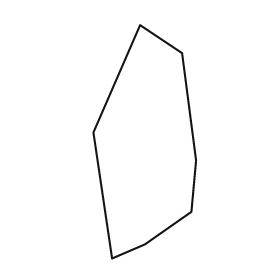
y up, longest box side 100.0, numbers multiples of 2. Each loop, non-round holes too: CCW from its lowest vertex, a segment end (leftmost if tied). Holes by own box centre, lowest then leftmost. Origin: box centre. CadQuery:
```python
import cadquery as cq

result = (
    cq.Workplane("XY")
    .moveTo(-14.0, -50.0)
    .lineTo(0.0, -44.0)
    .lineTo(20.0, -30.0)
    .lineTo(22.0, -8.0)
    .lineTo(16.0, 38.0)
    .lineTo(-2.0, 50.0)
    .lineTo(-22.0, 4.0)
    .close()
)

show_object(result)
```